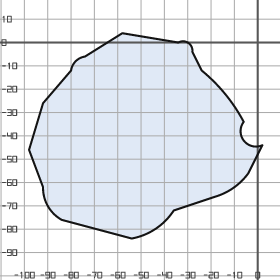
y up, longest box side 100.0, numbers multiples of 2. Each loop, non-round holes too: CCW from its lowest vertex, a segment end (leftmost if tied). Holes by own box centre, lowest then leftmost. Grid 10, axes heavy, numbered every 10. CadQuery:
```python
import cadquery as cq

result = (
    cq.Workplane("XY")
    .moveTo(-54.0, -84.0)
    .threePointArc((-44.0, -80.0), (-36.0, -72.0))
    .lineTo(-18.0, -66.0)
    .threePointArc((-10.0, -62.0), (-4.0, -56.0))
    .lineTo(2.0, -44.0)
    .threePointArc((-6.0, -42.0), (-6.0, -34.0))
    .threePointArc((-14.0, -22.0), (-24.0, -12.0))
    .lineTo(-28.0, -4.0)
    .threePointArc((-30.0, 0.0), (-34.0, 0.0))
    .lineTo(-58.0, 4.0)
    .lineTo(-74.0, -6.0)
    .threePointArc((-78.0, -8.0), (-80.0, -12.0))
    .lineTo(-92.0, -26.0)
    .lineTo(-98.0, -46.0)
    .lineTo(-92.0, -62.0)
    .threePointArc((-90.0, -70.0), (-84.0, -76.0))
    .close()
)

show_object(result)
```